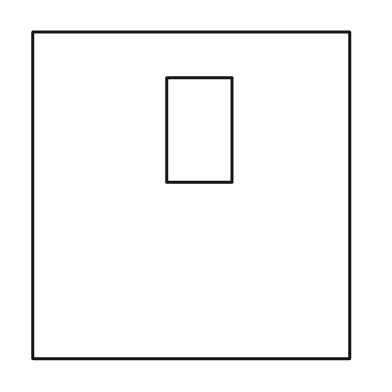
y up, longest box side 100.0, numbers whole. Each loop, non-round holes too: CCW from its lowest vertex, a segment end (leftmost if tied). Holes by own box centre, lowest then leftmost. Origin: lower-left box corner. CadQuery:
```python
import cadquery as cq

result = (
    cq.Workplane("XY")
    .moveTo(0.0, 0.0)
    .lineTo(97.0, 0.0)
    .lineTo(97.0, 100.0)
    .lineTo(0.0, 100.0)
    .close()
    .moveTo(41.0, 54.0)
    .lineTo(61.0, 54.0)
    .lineTo(61.0, 86.0)
    .lineTo(41.0, 86.0)
    .close()
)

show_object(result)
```